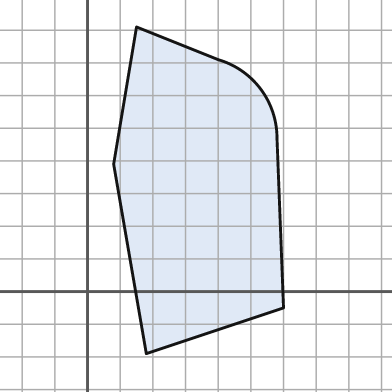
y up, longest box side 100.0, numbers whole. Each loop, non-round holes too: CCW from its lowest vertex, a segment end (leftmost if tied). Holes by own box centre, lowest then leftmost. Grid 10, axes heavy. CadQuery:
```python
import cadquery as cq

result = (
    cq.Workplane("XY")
    .moveTo(18.0, -19.0)
    .lineTo(60.0, -5.0)
    .lineTo(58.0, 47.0)
    .threePointArc((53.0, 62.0), (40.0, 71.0))
    .lineTo(15.0, 81.0)
    .lineTo(8.0, 39.0)
    .close()
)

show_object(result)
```